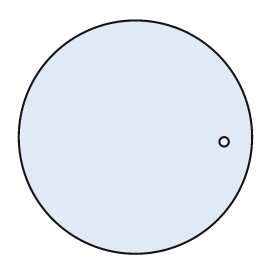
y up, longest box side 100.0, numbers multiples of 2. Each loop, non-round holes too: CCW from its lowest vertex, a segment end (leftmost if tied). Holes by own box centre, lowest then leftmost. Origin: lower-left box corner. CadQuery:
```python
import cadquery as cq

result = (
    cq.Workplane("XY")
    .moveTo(50.0, 50.0)
    .circle(50.0)
    .moveTo(88.0, 48.0)
    .circle(2.0)
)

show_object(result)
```